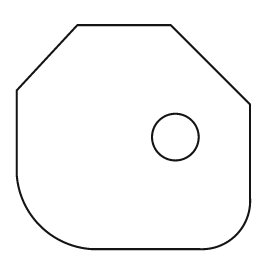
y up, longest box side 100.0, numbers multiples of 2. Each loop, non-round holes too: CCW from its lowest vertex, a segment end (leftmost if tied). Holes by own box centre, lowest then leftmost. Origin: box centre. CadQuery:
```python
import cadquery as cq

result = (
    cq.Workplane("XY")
    .moveTo(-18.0, -48.0)
    .lineTo(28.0, -48.0)
    .threePointArc((44.0, -42.0), (50.0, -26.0))
    .lineTo(50.0, 14.0)
    .lineTo(16.0, 48.0)
    .lineTo(-24.0, 48.0)
    .lineTo(-50.0, 20.0)
    .lineTo(-50.0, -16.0)
    .threePointArc((-40.0, -38.0), (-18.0, -48.0))
    .close()
    .moveTo(18.0, 0.0)
    .circle(10.0)
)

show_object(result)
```